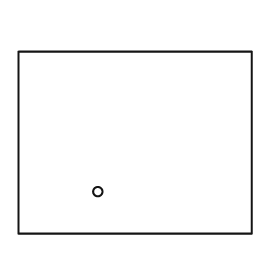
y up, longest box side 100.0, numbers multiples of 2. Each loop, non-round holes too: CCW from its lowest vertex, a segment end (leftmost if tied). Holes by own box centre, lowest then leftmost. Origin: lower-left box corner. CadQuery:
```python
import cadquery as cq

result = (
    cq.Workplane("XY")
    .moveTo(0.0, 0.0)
    .lineTo(100.0, 0.0)
    .lineTo(100.0, 78.0)
    .lineTo(0.0, 78.0)
    .close()
    .moveTo(34.0, 18.0)
    .circle(2.0)
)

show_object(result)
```